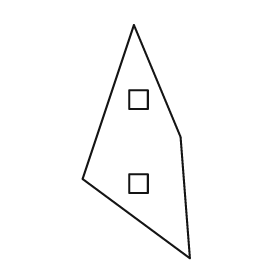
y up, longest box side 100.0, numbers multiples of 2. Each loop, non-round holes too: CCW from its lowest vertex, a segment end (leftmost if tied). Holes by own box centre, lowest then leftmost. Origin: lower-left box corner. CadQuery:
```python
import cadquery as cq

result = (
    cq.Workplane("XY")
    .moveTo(46.0, 0.0)
    .lineTo(42.0, 52.0)
    .lineTo(22.0, 100.0)
    .lineTo(0.0, 34.0)
    .close()
    .moveTo(20.0, 28.0)
    .lineTo(28.0, 28.0)
    .lineTo(28.0, 36.0)
    .lineTo(20.0, 36.0)
    .close()
    .moveTo(20.0, 64.0)
    .lineTo(28.0, 64.0)
    .lineTo(28.0, 72.0)
    .lineTo(20.0, 72.0)
    .close()
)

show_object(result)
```